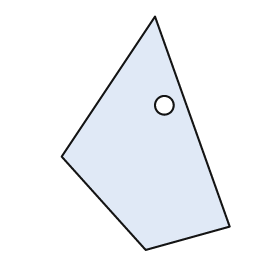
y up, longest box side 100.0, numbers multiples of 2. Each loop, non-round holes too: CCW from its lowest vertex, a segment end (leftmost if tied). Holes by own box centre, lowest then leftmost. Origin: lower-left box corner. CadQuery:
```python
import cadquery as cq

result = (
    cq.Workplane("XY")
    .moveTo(36.0, 0.0)
    .lineTo(72.0, 10.0)
    .lineTo(40.0, 100.0)
    .lineTo(0.0, 40.0)
    .close()
    .moveTo(44.0, 62.0)
    .circle(4.0)
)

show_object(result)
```